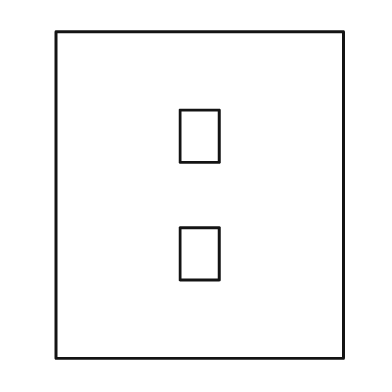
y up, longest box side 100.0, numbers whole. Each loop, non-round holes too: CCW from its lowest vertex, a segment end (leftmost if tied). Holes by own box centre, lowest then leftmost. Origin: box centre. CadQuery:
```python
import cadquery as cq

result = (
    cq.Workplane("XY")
    .moveTo(-44.0, -50.0)
    .lineTo(44.0, -50.0)
    .lineTo(44.0, 50.0)
    .lineTo(-44.0, 50.0)
    .close()
    .moveTo(-6.0, -26.0)
    .lineTo(6.0, -26.0)
    .lineTo(6.0, -10.0)
    .lineTo(-6.0, -10.0)
    .close()
    .moveTo(-6.0, 10.0)
    .lineTo(6.0, 10.0)
    .lineTo(6.0, 26.0)
    .lineTo(-6.0, 26.0)
    .close()
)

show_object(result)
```